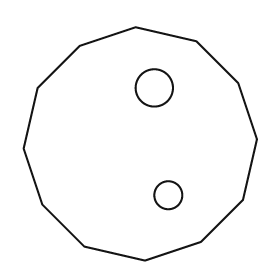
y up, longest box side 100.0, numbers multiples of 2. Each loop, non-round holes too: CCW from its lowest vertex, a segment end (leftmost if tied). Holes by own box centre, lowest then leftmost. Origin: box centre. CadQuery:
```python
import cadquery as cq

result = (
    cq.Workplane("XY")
    .moveTo(2.0, -50.0)
    .lineTo(26.0, -42.0)
    .lineTo(44.0, -24.0)
    .lineTo(50.0, 2.0)
    .lineTo(42.0, 26.0)
    .lineTo(24.0, 44.0)
    .lineTo(-2.0, 50.0)
    .lineTo(-26.0, 42.0)
    .lineTo(-44.0, 24.0)
    .lineTo(-50.0, -2.0)
    .lineTo(-42.0, -26.0)
    .lineTo(-24.0, -44.0)
    .close()
    .moveTo(12.0, -22.0)
    .circle(6.0)
    .moveTo(6.0, 24.0)
    .circle(8.0)
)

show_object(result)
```